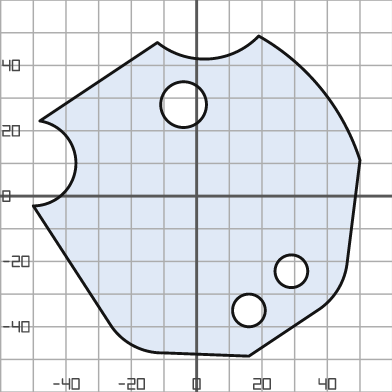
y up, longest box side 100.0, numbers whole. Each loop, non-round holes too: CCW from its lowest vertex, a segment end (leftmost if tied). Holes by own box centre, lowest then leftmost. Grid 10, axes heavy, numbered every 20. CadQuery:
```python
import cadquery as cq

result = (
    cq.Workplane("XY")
    .moveTo(16.0, -49.0)
    .lineTo(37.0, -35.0)
    .threePointArc((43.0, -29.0), (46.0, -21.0))
    .lineTo(50.0, 11.0)
    .threePointArc((38.0, 33.0), (19.0, 49.0))
    .threePointArc((4.0, 42.0), (-12.0, 47.0))
    .lineTo(-48.0, 23.0)
    .threePointArc((-37.0, 9.0), (-50.0, -3.0))
    .lineTo(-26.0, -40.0)
    .threePointArc((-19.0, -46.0), (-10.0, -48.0))
    .close()
    .moveTo(16.0, -35.0)
    .circle(5.0)
    .moveTo(29.0, -23.0)
    .circle(5.0)
    .moveTo(-4.0, 28.0)
    .circle(7.0)
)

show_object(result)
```